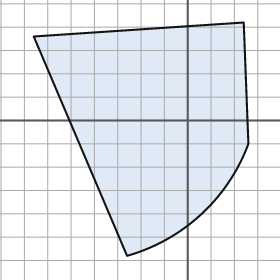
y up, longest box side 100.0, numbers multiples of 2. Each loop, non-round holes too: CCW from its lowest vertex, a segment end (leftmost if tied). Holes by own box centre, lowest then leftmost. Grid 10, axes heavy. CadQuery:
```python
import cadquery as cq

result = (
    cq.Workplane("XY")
    .moveTo(-26.0, -58.0)
    .threePointArc((6.0, -40.0), (26.0, -10.0))
    .lineTo(24.0, 42.0)
    .lineTo(-66.0, 36.0)
    .close()
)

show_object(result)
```